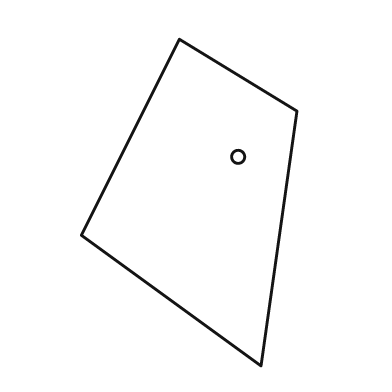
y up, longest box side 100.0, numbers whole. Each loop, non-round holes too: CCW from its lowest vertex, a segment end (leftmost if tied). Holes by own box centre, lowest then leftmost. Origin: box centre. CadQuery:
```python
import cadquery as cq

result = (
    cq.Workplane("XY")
    .moveTo(22.0, -50.0)
    .lineTo(33.0, 28.0)
    .lineTo(-3.0, 50.0)
    .lineTo(-33.0, -10.0)
    .close()
    .moveTo(15.0, 14.0)
    .circle(2.0)
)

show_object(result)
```